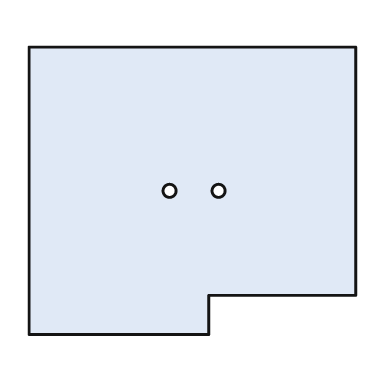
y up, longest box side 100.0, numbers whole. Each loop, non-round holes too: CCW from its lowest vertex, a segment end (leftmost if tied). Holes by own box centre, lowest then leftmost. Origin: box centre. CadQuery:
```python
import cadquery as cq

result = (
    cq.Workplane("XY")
    .moveTo(-50.0, -44.0)
    .lineTo(5.0, -44.0)
    .lineTo(5.0, -32.0)
    .lineTo(50.0, -32.0)
    .lineTo(50.0, 44.0)
    .lineTo(-50.0, 44.0)
    .close()
    .moveTo(-7.0, 0.0)
    .circle(2.0)
    .moveTo(8.0, 0.0)
    .circle(2.0)
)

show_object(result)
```